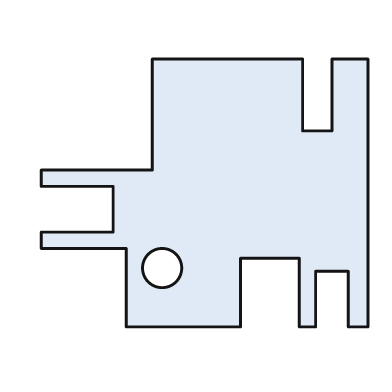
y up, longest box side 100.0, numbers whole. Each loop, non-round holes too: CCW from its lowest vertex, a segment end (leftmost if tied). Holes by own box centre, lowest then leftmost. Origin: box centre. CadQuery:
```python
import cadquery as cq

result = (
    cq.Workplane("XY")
    .moveTo(-24.0, -41.0)
    .lineTo(11.0, -41.0)
    .lineTo(11.0, -20.0)
    .lineTo(29.0, -20.0)
    .lineTo(29.0, -41.0)
    .lineTo(34.0, -41.0)
    .lineTo(34.0, -24.0)
    .lineTo(44.0, -24.0)
    .lineTo(44.0, -41.0)
    .lineTo(50.0, -41.0)
    .lineTo(50.0, 41.0)
    .lineTo(39.0, 41.0)
    .lineTo(39.0, 19.0)
    .lineTo(30.0, 19.0)
    .lineTo(30.0, 41.0)
    .lineTo(-16.0, 41.0)
    .lineTo(-16.0, 7.0)
    .lineTo(-50.0, 7.0)
    .lineTo(-50.0, 2.0)
    .lineTo(-28.0, 2.0)
    .lineTo(-28.0, -12.0)
    .lineTo(-50.0, -12.0)
    .lineTo(-50.0, -17.0)
    .lineTo(-24.0, -17.0)
    .close()
    .moveTo(-13.0, -23.0)
    .circle(6.0)
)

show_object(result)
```